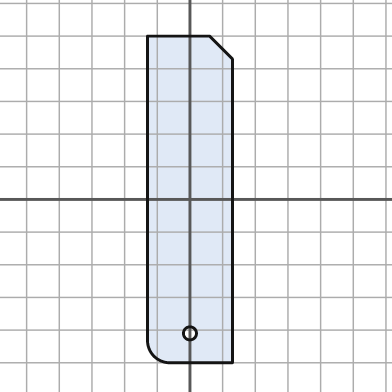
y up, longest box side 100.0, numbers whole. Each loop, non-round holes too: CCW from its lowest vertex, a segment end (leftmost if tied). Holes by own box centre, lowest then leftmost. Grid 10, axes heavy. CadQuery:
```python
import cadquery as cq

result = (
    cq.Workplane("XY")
    .moveTo(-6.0, -50.0)
    .lineTo(13.0, -50.0)
    .lineTo(13.0, 43.0)
    .lineTo(6.0, 50.0)
    .lineTo(-13.0, 50.0)
    .lineTo(-13.0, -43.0)
    .threePointArc((-11.0, -48.0), (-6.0, -50.0))
    .close()
    .moveTo(0.0, -41.0)
    .circle(2.0)
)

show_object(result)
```